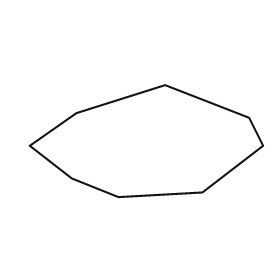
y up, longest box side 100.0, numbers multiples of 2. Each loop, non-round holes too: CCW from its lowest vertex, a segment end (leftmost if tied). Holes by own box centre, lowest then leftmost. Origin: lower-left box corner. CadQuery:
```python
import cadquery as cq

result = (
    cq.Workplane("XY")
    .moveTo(38.0, 0.0)
    .lineTo(74.0, 2.0)
    .lineTo(100.0, 22.0)
    .lineTo(94.0, 34.0)
    .lineTo(58.0, 48.0)
    .lineTo(20.0, 36.0)
    .lineTo(0.0, 22.0)
    .lineTo(18.0, 8.0)
    .close()
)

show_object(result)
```